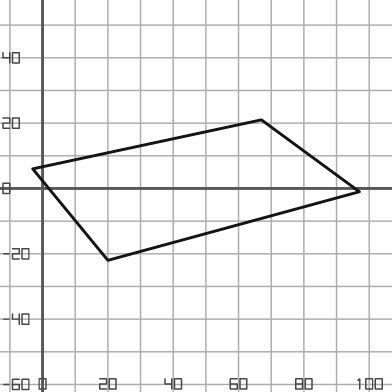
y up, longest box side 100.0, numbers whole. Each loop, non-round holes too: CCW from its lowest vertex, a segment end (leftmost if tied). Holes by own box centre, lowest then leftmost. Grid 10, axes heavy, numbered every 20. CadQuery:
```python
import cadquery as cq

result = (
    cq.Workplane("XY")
    .moveTo(20.0, -22.0)
    .lineTo(97.0, -1.0)
    .lineTo(67.0, 21.0)
    .lineTo(-3.0, 6.0)
    .close()
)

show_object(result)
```